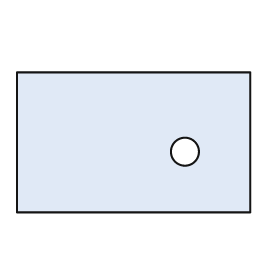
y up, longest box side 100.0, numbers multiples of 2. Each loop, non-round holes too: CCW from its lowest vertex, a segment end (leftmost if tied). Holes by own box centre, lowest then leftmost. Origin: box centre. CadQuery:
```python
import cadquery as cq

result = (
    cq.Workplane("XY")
    .moveTo(-50.0, -30.0)
    .lineTo(50.0, -30.0)
    .lineTo(50.0, 30.0)
    .lineTo(-50.0, 30.0)
    .close()
    .moveTo(22.0, -4.0)
    .circle(6.0)
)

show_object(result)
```